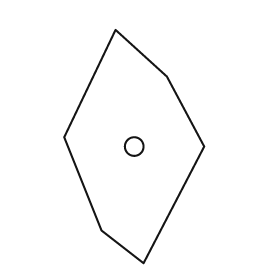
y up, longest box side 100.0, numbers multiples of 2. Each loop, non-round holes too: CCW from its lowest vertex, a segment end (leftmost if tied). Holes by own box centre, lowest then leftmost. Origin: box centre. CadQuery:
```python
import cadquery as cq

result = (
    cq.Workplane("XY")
    .moveTo(4.0, -50.0)
    .lineTo(30.0, 0.0)
    .lineTo(14.0, 30.0)
    .lineTo(-8.0, 50.0)
    .lineTo(-30.0, 4.0)
    .lineTo(-14.0, -36.0)
    .close()
    .moveTo(0.0, 0.0)
    .circle(4.0)
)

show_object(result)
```